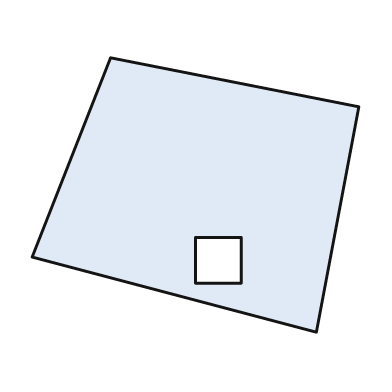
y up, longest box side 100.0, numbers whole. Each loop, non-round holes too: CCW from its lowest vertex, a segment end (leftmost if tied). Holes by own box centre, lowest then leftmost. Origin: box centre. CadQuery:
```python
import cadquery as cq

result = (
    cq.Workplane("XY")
    .moveTo(37.0, -42.0)
    .lineTo(50.0, 27.0)
    .lineTo(-26.0, 42.0)
    .lineTo(-50.0, -19.0)
    .close()
    .moveTo(0.0, -27.0)
    .lineTo(14.0, -27.0)
    .lineTo(14.0, -13.0)
    .lineTo(0.0, -13.0)
    .close()
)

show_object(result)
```